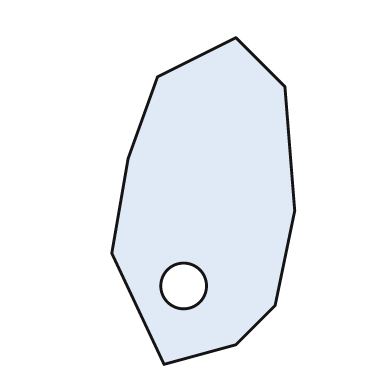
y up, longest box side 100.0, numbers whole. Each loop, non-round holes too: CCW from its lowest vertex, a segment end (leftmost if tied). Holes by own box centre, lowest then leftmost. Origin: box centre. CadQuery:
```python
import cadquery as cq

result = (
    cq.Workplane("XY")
    .moveTo(-12.0, -50.0)
    .lineTo(10.0, -44.0)
    .lineTo(22.0, -32.0)
    .lineTo(28.0, -3.0)
    .lineTo(25.0, 35.0)
    .lineTo(10.0, 50.0)
    .lineTo(-14.0, 38.0)
    .lineTo(-23.0, 13.0)
    .lineTo(-28.0, -16.0)
    .close()
    .moveTo(-6.0, -26.0)
    .circle(7.0)
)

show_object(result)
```